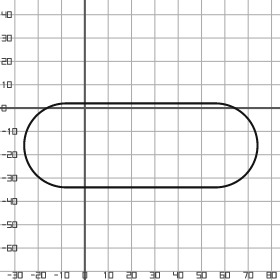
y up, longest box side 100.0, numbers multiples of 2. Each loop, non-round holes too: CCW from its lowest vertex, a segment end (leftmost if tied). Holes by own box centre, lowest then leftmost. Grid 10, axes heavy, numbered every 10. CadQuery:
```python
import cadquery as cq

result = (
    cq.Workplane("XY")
    .moveTo(-8.0, -34.0)
    .lineTo(56.0, -34.0)
    .threePointArc((74.0, -16.0), (56.0, 2.0))
    .lineTo(-8.0, 2.0)
    .threePointArc((-26.0, -16.0), (-8.0, -34.0))
    .close()
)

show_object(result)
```